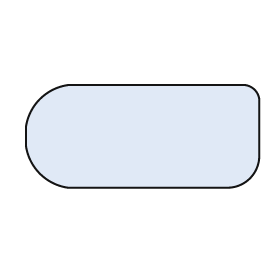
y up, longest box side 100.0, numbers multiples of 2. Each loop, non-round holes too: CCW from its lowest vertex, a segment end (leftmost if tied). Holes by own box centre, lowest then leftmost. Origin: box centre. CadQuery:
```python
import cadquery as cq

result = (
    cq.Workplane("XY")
    .moveTo(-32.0, -22.0)
    .lineTo(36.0, -22.0)
    .threePointArc((46.0, -18.0), (50.0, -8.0))
    .lineTo(50.0, 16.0)
    .threePointArc((48.0, 20.0), (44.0, 22.0))
    .lineTo(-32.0, 22.0)
    .threePointArc((-44.0, 16.0), (-50.0, 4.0))
    .lineTo(-50.0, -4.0)
    .threePointArc((-44.0, -16.0), (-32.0, -22.0))
    .close()
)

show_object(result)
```